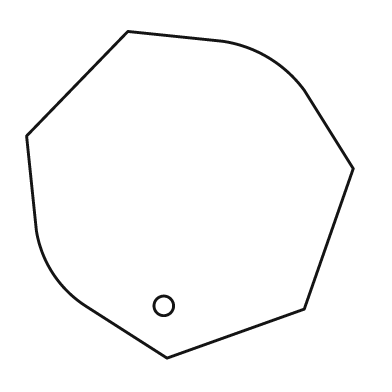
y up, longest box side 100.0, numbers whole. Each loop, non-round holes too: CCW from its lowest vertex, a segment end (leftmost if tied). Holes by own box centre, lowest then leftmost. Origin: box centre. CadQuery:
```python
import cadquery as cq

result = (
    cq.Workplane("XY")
    .moveTo(-7.0, -50.0)
    .lineTo(35.0, -35.0)
    .lineTo(50.0, 8.0)
    .lineTo(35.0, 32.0)
    .threePointArc((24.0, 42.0), (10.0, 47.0))
    .lineTo(-19.0, 50.0)
    .lineTo(-50.0, 18.0)
    .lineTo(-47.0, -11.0)
    .threePointArc((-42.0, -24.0), (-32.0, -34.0))
    .close()
    .moveTo(-8.0, -34.0)
    .circle(3.0)
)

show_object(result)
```